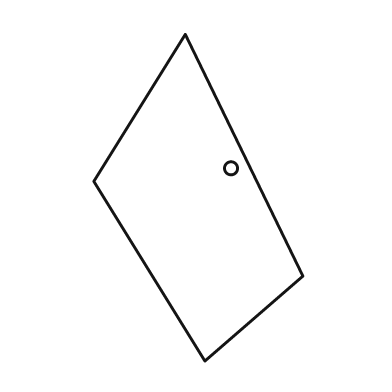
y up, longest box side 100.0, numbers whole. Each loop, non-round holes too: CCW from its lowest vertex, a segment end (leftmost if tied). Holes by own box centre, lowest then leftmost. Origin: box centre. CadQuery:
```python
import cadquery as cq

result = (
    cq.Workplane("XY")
    .moveTo(2.0, -50.0)
    .lineTo(32.0, -24.0)
    .lineTo(-4.0, 50.0)
    .lineTo(-32.0, 5.0)
    .close()
    .moveTo(10.0, 9.0)
    .circle(2.0)
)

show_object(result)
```